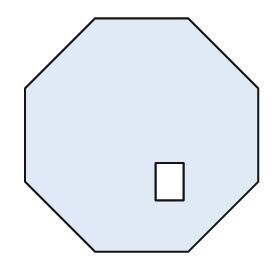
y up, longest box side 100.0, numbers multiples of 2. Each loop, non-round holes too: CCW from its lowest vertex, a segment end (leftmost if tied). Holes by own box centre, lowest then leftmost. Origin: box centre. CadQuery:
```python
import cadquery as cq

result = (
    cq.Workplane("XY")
    .moveTo(-20.0, -50.0)
    .lineTo(20.0, -50.0)
    .lineTo(50.0, -20.0)
    .lineTo(50.0, 20.0)
    .lineTo(20.0, 50.0)
    .lineTo(-20.0, 50.0)
    .lineTo(-50.0, 20.0)
    .lineTo(-50.0, -20.0)
    .close()
    .moveTo(6.0, -28.0)
    .lineTo(18.0, -28.0)
    .lineTo(18.0, -12.0)
    .lineTo(6.0, -12.0)
    .close()
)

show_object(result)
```